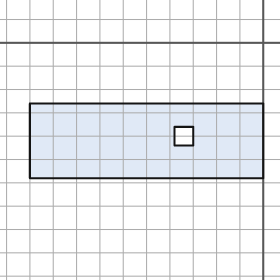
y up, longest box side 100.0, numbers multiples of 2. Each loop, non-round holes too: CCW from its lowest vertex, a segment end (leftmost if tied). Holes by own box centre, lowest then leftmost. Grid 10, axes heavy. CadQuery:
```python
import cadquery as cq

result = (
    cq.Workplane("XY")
    .moveTo(-100.0, -58.0)
    .lineTo(0.0, -58.0)
    .lineTo(0.0, -26.0)
    .lineTo(-100.0, -26.0)
    .close()
    .moveTo(-38.0, -44.0)
    .lineTo(-30.0, -44.0)
    .lineTo(-30.0, -36.0)
    .lineTo(-38.0, -36.0)
    .close()
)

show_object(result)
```